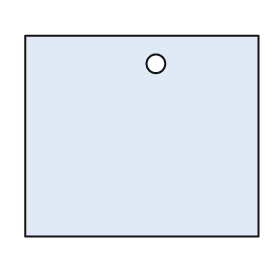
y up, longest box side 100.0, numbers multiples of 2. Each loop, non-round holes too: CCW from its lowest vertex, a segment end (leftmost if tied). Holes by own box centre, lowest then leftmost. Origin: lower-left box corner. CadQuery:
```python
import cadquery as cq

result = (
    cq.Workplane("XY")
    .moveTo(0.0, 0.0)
    .lineTo(100.0, 0.0)
    .lineTo(100.0, 86.0)
    .lineTo(0.0, 86.0)
    .close()
    .moveTo(56.0, 74.0)
    .circle(4.0)
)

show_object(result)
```